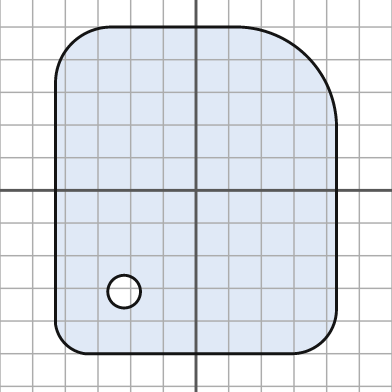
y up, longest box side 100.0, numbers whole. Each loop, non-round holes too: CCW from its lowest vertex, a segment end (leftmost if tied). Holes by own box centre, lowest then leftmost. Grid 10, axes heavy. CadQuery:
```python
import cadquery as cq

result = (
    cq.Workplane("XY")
    .moveTo(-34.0, -50.0)
    .lineTo(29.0, -50.0)
    .threePointArc((39.0, -46.0), (43.0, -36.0))
    .lineTo(43.0, 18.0)
    .threePointArc((34.0, 41.0), (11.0, 50.0))
    .lineTo(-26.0, 50.0)
    .threePointArc((-38.0, 45.0), (-43.0, 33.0))
    .lineTo(-43.0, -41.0)
    .threePointArc((-40.0, -47.0), (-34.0, -50.0))
    .close()
    .moveTo(-22.0, -31.0)
    .circle(5.0)
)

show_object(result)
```